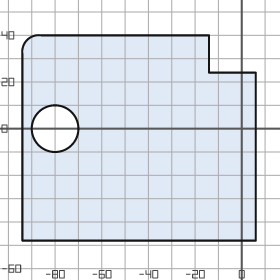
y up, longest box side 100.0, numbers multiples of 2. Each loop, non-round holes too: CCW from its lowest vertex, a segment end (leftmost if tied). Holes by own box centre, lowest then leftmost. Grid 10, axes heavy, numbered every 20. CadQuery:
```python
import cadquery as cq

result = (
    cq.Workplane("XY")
    .moveTo(-94.0, -48.0)
    .lineTo(6.0, -48.0)
    .lineTo(6.0, 24.0)
    .lineTo(-14.0, 24.0)
    .lineTo(-14.0, 40.0)
    .lineTo(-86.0, 40.0)
    .threePointArc((-92.0, 38.0), (-94.0, 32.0))
    .close()
    .moveTo(-80.0, 0.0)
    .circle(10.0)
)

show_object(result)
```